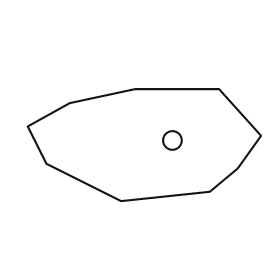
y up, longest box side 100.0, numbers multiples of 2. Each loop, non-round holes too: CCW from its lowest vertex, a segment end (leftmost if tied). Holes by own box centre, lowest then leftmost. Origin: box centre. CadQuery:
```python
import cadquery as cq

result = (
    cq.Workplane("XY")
    .moveTo(-10.0, -24.0)
    .lineTo(28.0, -20.0)
    .lineTo(40.0, -10.0)
    .lineTo(50.0, 4.0)
    .lineTo(32.0, 24.0)
    .lineTo(-4.0, 24.0)
    .lineTo(-32.0, 18.0)
    .lineTo(-50.0, 8.0)
    .lineTo(-42.0, -8.0)
    .close()
    .moveTo(12.0, 2.0)
    .circle(4.0)
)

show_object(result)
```